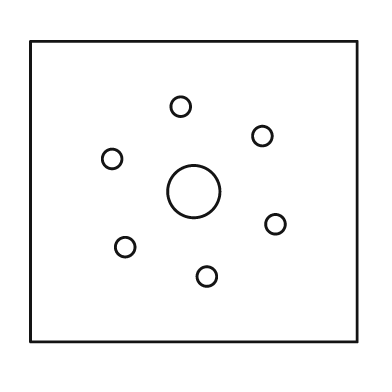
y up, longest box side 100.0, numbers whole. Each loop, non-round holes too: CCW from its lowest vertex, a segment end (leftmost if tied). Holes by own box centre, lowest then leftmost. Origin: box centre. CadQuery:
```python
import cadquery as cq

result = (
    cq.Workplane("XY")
    .moveTo(-50.0, -46.0)
    .lineTo(50.0, -46.0)
    .lineTo(50.0, 46.0)
    .lineTo(-50.0, 46.0)
    .close()
    .moveTo(4.0, -26.0)
    .circle(3.0)
    .moveTo(-21.0, -17.0)
    .circle(3.0)
    .moveTo(25.0, -10.0)
    .circle(3.0)
    .moveTo(0.0, 0.0)
    .circle(8.0)
    .moveTo(-25.0, 10.0)
    .circle(3.0)
    .moveTo(21.0, 17.0)
    .circle(3.0)
    .moveTo(-4.0, 26.0)
    .circle(3.0)
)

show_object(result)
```